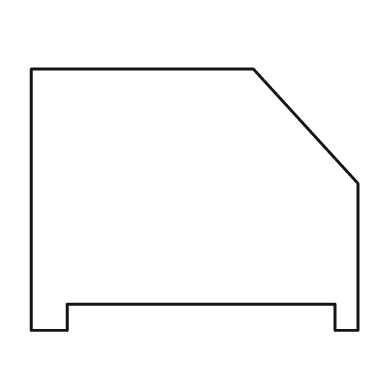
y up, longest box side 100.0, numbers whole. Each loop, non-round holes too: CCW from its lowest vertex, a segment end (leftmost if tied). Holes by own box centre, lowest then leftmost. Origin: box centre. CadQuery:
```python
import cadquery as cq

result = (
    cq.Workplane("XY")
    .moveTo(-50.0, -40.0)
    .lineTo(-39.0, -40.0)
    .lineTo(-39.0, -32.0)
    .lineTo(43.0, -32.0)
    .lineTo(43.0, -40.0)
    .lineTo(50.0, -40.0)
    .lineTo(50.0, 5.0)
    .lineTo(18.0, 40.0)
    .lineTo(-50.0, 40.0)
    .close()
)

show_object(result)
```